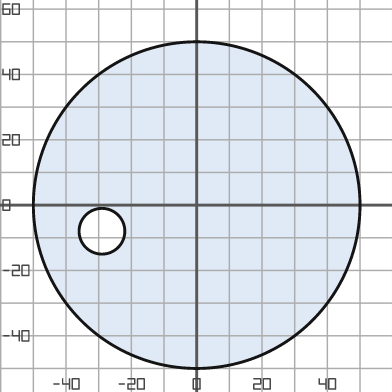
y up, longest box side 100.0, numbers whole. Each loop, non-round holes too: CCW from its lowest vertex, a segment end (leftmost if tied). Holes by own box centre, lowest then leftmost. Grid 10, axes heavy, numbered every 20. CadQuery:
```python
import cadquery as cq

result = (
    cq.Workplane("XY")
    .moveTo(0.0, 0.0)
    .circle(50.0)
    .moveTo(-29.0, -8.0)
    .circle(7.0)
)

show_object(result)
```